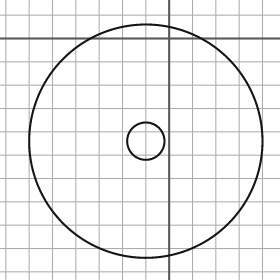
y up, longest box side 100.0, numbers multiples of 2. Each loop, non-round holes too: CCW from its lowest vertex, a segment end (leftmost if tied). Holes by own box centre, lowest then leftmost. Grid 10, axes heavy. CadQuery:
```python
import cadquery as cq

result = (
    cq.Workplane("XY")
    .moveTo(-10.0, -44.0)
    .circle(50.0)
    .moveTo(-10.0, -44.0)
    .circle(8.0)
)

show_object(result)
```